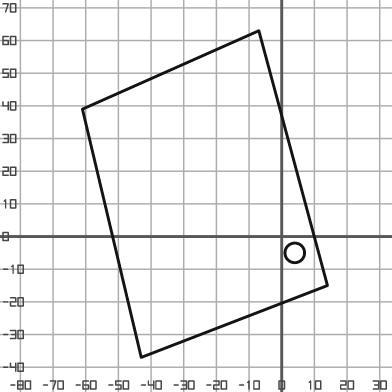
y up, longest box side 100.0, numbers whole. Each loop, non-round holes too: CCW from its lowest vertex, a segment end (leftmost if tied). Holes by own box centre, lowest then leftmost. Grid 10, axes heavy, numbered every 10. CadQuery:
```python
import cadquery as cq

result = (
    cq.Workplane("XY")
    .moveTo(-43.0, -37.0)
    .lineTo(14.0, -15.0)
    .lineTo(-7.0, 63.0)
    .lineTo(-61.0, 39.0)
    .close()
    .moveTo(4.0, -5.0)
    .circle(3.0)
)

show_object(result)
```